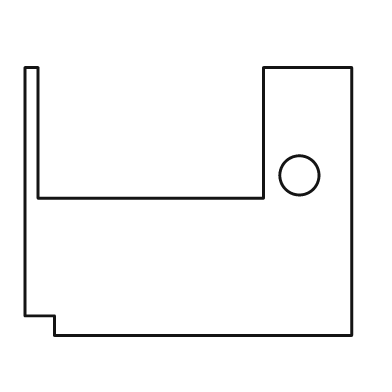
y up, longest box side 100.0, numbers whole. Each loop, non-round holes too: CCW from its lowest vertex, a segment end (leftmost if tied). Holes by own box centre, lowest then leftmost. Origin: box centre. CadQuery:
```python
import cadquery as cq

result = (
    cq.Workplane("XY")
    .moveTo(-41.0, -41.0)
    .lineTo(50.0, -41.0)
    .lineTo(50.0, 41.0)
    .lineTo(23.0, 41.0)
    .lineTo(23.0, 1.0)
    .lineTo(-46.0, 1.0)
    .lineTo(-46.0, 41.0)
    .lineTo(-50.0, 41.0)
    .lineTo(-50.0, -35.0)
    .lineTo(-41.0, -35.0)
    .close()
    .moveTo(34.0, 8.0)
    .circle(6.0)
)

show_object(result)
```